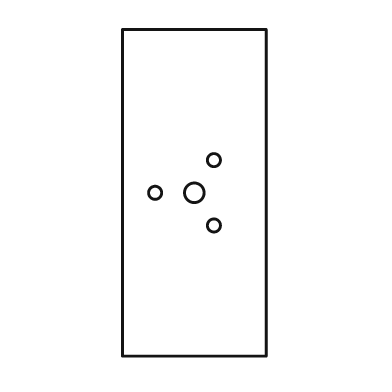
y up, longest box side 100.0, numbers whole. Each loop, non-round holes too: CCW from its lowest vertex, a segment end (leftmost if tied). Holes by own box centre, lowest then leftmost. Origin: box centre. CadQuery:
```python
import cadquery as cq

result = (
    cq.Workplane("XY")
    .moveTo(-22.0, -50.0)
    .lineTo(22.0, -50.0)
    .lineTo(22.0, 50.0)
    .lineTo(-22.0, 50.0)
    .close()
    .moveTo(6.0, -10.0)
    .circle(2.0)
    .moveTo(-12.0, 0.0)
    .circle(2.0)
    .moveTo(0.0, 0.0)
    .circle(3.0)
    .moveTo(6.0, 10.0)
    .circle(2.0)
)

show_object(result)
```